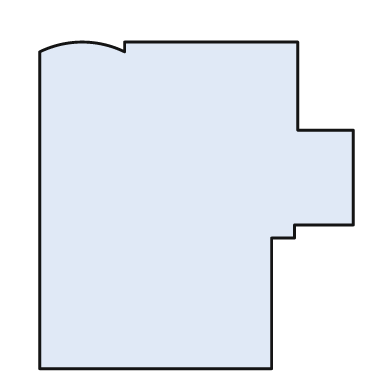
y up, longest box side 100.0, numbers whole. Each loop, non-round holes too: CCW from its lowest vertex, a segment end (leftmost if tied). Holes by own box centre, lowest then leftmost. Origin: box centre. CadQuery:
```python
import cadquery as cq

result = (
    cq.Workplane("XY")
    .moveTo(-48.0, -50.0)
    .lineTo(23.0, -50.0)
    .lineTo(23.0, -10.0)
    .lineTo(30.0, -10.0)
    .lineTo(30.0, -6.0)
    .lineTo(48.0, -6.0)
    .lineTo(48.0, 23.0)
    .lineTo(31.0, 23.0)
    .lineTo(31.0, 50.0)
    .lineTo(-22.0, 50.0)
    .lineTo(-22.0, 47.0)
    .threePointArc((-35.0, 50.0), (-48.0, 47.0))
    .close()
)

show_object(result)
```